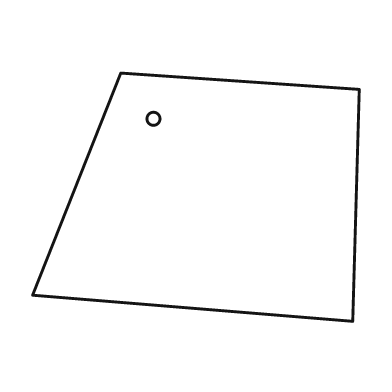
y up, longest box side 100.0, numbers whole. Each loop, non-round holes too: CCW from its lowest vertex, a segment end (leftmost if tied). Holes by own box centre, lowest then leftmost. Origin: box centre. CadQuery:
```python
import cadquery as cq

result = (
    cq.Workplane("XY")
    .moveTo(48.0, -38.0)
    .lineTo(50.0, 33.0)
    .lineTo(-23.0, 38.0)
    .lineTo(-50.0, -30.0)
    .close()
    .moveTo(-13.0, 24.0)
    .circle(2.0)
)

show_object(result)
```